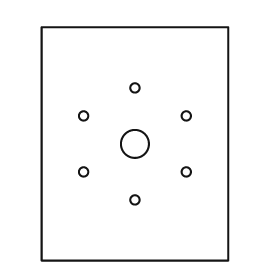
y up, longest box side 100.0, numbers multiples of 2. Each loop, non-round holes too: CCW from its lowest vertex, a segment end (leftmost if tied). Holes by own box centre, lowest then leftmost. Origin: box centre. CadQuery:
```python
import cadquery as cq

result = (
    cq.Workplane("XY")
    .moveTo(-40.0, -50.0)
    .lineTo(40.0, -50.0)
    .lineTo(40.0, 50.0)
    .lineTo(-40.0, 50.0)
    .close()
    .moveTo(0.0, -24.0)
    .circle(2.0)
    .moveTo(-22.0, -12.0)
    .circle(2.0)
    .moveTo(22.0, -12.0)
    .circle(2.0)
    .moveTo(0.0, 0.0)
    .circle(6.0)
    .moveTo(-22.0, 12.0)
    .circle(2.0)
    .moveTo(22.0, 12.0)
    .circle(2.0)
    .moveTo(0.0, 24.0)
    .circle(2.0)
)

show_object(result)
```